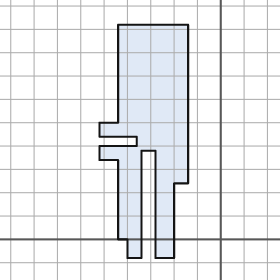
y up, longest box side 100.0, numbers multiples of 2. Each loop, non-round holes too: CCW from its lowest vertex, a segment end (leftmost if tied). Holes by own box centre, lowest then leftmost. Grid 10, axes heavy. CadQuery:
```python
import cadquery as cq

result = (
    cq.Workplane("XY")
    .moveTo(-40.0, -8.0)
    .lineTo(-34.0, -8.0)
    .lineTo(-34.0, 38.0)
    .lineTo(-28.0, 38.0)
    .lineTo(-28.0, -8.0)
    .lineTo(-20.0, -8.0)
    .lineTo(-20.0, 24.0)
    .lineTo(-14.0, 24.0)
    .lineTo(-14.0, 92.0)
    .lineTo(-44.0, 92.0)
    .lineTo(-44.0, 50.0)
    .lineTo(-52.0, 50.0)
    .lineTo(-52.0, 44.0)
    .lineTo(-36.0, 44.0)
    .lineTo(-36.0, 40.0)
    .lineTo(-52.0, 40.0)
    .lineTo(-52.0, 34.0)
    .lineTo(-44.0, 34.0)
    .lineTo(-44.0, 0.0)
    .lineTo(-40.0, 0.0)
    .close()
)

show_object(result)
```